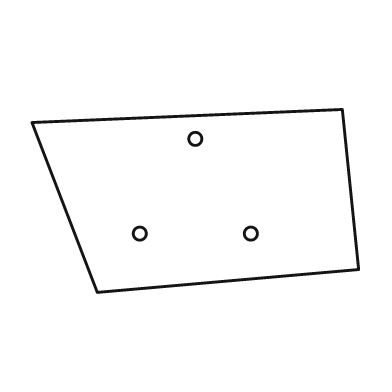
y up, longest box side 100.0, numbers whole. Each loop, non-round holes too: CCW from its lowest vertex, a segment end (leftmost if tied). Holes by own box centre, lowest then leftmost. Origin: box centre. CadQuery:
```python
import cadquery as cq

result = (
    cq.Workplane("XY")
    .moveTo(-30.0, -28.0)
    .lineTo(50.0, -21.0)
    .lineTo(45.0, 28.0)
    .lineTo(-50.0, 24.0)
    .close()
    .moveTo(-17.0, -10.0)
    .circle(2.0)
    .moveTo(17.0, -10.0)
    .circle(2.0)
    .moveTo(0.0, 19.0)
    .circle(2.0)
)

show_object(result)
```